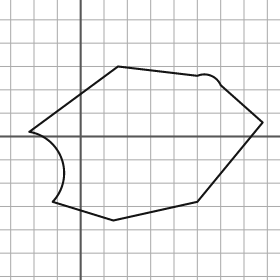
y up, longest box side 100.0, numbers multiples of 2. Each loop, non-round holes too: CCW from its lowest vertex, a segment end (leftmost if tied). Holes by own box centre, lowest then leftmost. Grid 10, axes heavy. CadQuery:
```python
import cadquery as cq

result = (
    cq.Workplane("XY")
    .moveTo(14.0, -36.0)
    .lineTo(50.0, -28.0)
    .lineTo(78.0, 6.0)
    .lineTo(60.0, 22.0)
    .threePointArc((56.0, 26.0), (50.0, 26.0))
    .lineTo(16.0, 30.0)
    .lineTo(-22.0, 2.0)
    .threePointArc((-8.0, -10.0), (-12.0, -28.0))
    .close()
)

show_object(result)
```